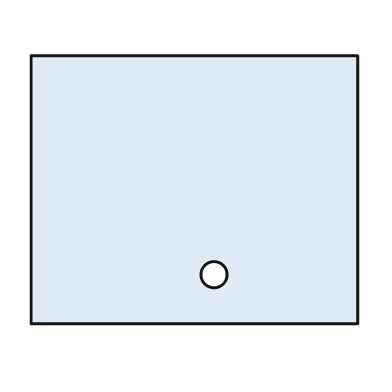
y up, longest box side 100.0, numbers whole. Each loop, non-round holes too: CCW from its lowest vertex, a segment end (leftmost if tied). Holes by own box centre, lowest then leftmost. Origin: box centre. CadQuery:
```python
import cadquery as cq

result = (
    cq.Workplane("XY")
    .moveTo(-50.0, -41.0)
    .lineTo(50.0, -41.0)
    .lineTo(50.0, 41.0)
    .lineTo(-50.0, 41.0)
    .close()
    .moveTo(6.0, -26.0)
    .circle(4.0)
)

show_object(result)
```